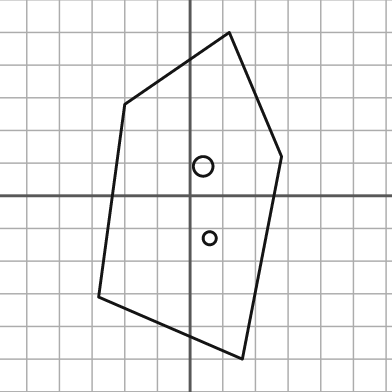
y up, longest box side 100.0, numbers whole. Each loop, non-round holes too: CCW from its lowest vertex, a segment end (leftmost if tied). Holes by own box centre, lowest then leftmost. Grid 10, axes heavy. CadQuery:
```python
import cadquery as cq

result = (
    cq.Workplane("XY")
    .moveTo(16.0, -50.0)
    .lineTo(28.0, 12.0)
    .lineTo(12.0, 50.0)
    .lineTo(-20.0, 28.0)
    .lineTo(-28.0, -31.0)
    .close()
    .moveTo(6.0, -13.0)
    .circle(2.0)
    .moveTo(4.0, 9.0)
    .circle(3.0)
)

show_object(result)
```